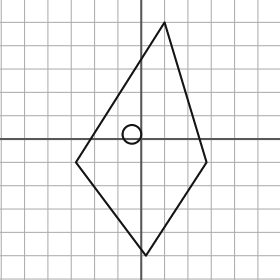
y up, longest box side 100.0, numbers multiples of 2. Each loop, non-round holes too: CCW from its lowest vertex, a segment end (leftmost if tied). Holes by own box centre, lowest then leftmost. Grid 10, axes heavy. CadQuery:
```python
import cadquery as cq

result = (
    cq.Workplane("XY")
    .moveTo(2.0, -50.0)
    .lineTo(28.0, -10.0)
    .lineTo(10.0, 50.0)
    .lineTo(-28.0, -10.0)
    .close()
    .moveTo(-4.0, 2.0)
    .circle(4.0)
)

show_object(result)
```